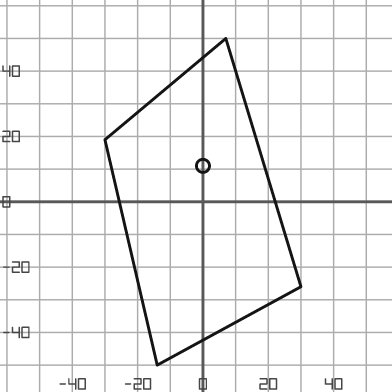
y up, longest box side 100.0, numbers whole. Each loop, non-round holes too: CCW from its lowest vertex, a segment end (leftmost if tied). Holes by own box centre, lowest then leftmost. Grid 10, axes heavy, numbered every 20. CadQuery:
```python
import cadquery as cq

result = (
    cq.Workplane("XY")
    .moveTo(-14.0, -50.0)
    .lineTo(30.0, -26.0)
    .lineTo(7.0, 50.0)
    .lineTo(-30.0, 19.0)
    .close()
    .moveTo(0.0, 11.0)
    .circle(2.0)
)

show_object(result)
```